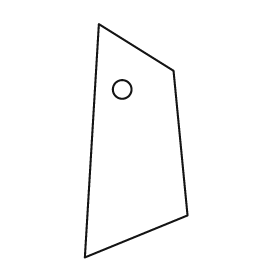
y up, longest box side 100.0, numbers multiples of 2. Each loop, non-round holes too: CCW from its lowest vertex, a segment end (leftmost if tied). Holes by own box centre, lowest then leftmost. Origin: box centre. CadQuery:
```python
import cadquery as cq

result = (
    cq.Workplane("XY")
    .moveTo(-22.0, -50.0)
    .lineTo(22.0, -32.0)
    .lineTo(16.0, 30.0)
    .lineTo(-16.0, 50.0)
    .close()
    .moveTo(-6.0, 22.0)
    .circle(4.0)
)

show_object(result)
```